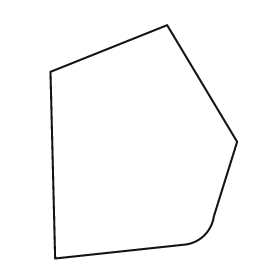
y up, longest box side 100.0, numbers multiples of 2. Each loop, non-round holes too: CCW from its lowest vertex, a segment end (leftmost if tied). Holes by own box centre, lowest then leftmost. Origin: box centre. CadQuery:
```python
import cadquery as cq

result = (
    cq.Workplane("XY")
    .moveTo(-38.0, -50.0)
    .lineTo(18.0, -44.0)
    .threePointArc((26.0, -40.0), (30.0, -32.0))
    .lineTo(40.0, 0.0)
    .lineTo(10.0, 50.0)
    .lineTo(-40.0, 30.0)
    .close()
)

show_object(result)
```